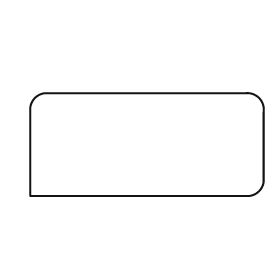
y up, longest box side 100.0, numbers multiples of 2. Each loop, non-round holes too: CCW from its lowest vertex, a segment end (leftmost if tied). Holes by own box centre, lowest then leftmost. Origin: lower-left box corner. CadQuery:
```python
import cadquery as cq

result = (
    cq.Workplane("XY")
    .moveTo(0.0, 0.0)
    .lineTo(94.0, 0.0)
    .threePointArc((98.0, 2.0), (100.0, 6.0))
    .lineTo(100.0, 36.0)
    .threePointArc((98.0, 42.0), (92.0, 44.0))
    .lineTo(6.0, 44.0)
    .threePointArc((2.0, 42.0), (0.0, 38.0))
    .close()
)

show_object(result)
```